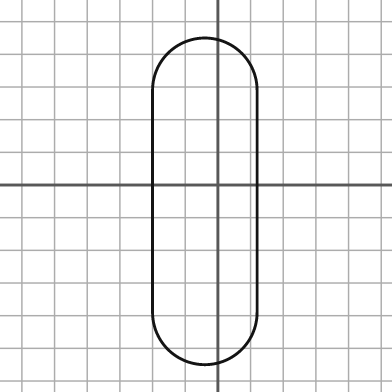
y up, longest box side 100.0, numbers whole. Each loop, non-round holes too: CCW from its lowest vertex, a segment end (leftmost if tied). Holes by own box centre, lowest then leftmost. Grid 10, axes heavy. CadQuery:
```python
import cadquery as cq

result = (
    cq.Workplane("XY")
    .moveTo(-20.0, -39.0)
    .threePointArc((-4.0, -55.0), (12.0, -39.0))
    .lineTo(12.0, 29.0)
    .threePointArc((-4.0, 45.0), (-20.0, 29.0))
    .close()
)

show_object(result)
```